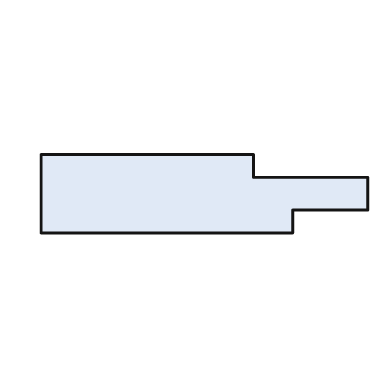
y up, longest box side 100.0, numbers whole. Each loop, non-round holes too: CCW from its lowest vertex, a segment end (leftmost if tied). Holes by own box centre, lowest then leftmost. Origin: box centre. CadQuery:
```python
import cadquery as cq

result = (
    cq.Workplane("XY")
    .moveTo(-50.0, -12.0)
    .lineTo(27.0, -12.0)
    .lineTo(27.0, -5.0)
    .lineTo(50.0, -5.0)
    .lineTo(50.0, 5.0)
    .lineTo(15.0, 5.0)
    .lineTo(15.0, 12.0)
    .lineTo(-50.0, 12.0)
    .close()
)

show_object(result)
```